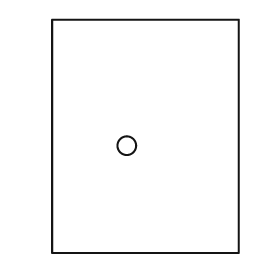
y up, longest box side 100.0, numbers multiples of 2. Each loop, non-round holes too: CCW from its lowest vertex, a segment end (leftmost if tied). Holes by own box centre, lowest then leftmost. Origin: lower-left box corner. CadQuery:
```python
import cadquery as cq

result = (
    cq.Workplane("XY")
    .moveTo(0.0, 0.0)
    .lineTo(80.0, 0.0)
    .lineTo(80.0, 100.0)
    .lineTo(0.0, 100.0)
    .close()
    .moveTo(32.0, 46.0)
    .circle(4.0)
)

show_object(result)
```